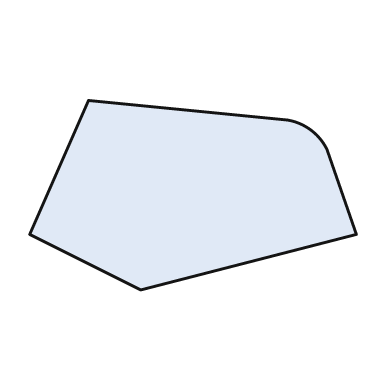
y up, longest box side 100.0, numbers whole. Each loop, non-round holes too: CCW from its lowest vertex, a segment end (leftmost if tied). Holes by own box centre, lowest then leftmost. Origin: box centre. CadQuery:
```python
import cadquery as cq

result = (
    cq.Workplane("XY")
    .moveTo(-16.0, -29.0)
    .lineTo(50.0, -12.0)
    .lineTo(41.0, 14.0)
    .threePointArc((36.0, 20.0), (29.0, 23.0))
    .lineTo(-32.0, 29.0)
    .lineTo(-50.0, -12.0)
    .close()
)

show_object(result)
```